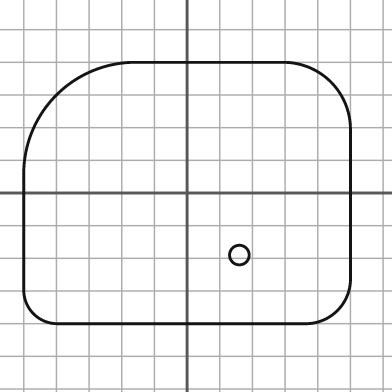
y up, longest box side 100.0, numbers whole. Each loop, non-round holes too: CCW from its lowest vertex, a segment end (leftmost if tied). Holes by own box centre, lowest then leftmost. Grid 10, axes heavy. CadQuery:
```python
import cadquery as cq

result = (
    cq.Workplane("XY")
    .moveTo(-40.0, -40.0)
    .lineTo(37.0, -40.0)
    .threePointArc((46.0, -36.0), (50.0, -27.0))
    .lineTo(50.0, 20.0)
    .threePointArc((44.0, 34.0), (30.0, 40.0))
    .lineTo(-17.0, 40.0)
    .threePointArc((-40.0, 30.0), (-50.0, 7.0))
    .lineTo(-50.0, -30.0)
    .threePointArc((-47.0, -37.0), (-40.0, -40.0))
    .close()
    .moveTo(16.0, -19.0)
    .circle(3.0)
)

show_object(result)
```